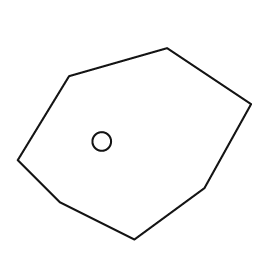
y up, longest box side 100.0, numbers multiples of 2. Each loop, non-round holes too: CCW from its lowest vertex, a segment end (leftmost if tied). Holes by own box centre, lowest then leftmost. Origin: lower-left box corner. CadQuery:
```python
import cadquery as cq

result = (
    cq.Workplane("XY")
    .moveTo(50.0, 0.0)
    .lineTo(80.0, 22.0)
    .lineTo(100.0, 58.0)
    .lineTo(64.0, 82.0)
    .lineTo(22.0, 70.0)
    .lineTo(0.0, 34.0)
    .lineTo(18.0, 16.0)
    .close()
    .moveTo(36.0, 42.0)
    .circle(4.0)
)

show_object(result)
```